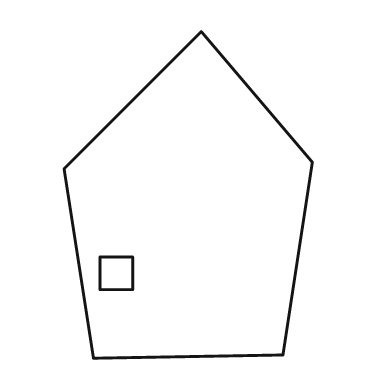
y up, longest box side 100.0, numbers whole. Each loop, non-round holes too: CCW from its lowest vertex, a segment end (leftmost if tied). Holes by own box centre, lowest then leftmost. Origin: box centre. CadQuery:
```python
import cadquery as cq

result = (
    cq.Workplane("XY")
    .moveTo(-29.0, -50.0)
    .lineTo(29.0, -49.0)
    .lineTo(38.0, 10.0)
    .lineTo(4.0, 50.0)
    .lineTo(-38.0, 8.0)
    .close()
    .moveTo(-27.0, -29.0)
    .lineTo(-17.0, -29.0)
    .lineTo(-17.0, -19.0)
    .lineTo(-27.0, -19.0)
    .close()
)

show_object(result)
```